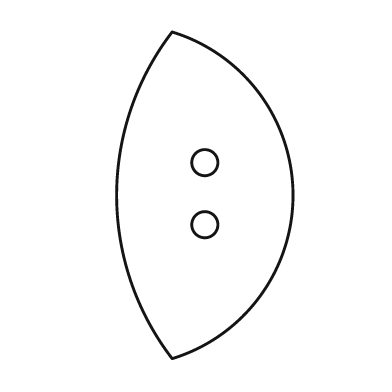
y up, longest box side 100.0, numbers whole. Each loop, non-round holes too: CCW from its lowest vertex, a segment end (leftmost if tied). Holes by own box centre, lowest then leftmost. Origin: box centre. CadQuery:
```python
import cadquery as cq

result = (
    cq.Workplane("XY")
    .moveTo(-10.0, -50.0)
    .threePointArc((27.0, 0.0), (-10.0, 50.0))
    .threePointArc((-27.0, 0.0), (-10.0, -50.0))
    .close()
    .moveTo(0.0, -9.0)
    .circle(4.0)
    .moveTo(0.0, 10.0)
    .circle(4.0)
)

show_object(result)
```